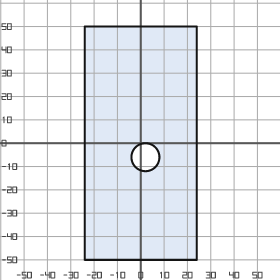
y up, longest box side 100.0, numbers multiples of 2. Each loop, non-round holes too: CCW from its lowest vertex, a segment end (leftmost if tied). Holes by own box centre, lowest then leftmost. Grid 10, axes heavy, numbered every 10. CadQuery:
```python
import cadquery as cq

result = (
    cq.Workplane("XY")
    .moveTo(-24.0, -50.0)
    .lineTo(24.0, -50.0)
    .lineTo(24.0, 50.0)
    .lineTo(-24.0, 50.0)
    .close()
    .moveTo(2.0, -6.0)
    .circle(6.0)
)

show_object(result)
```